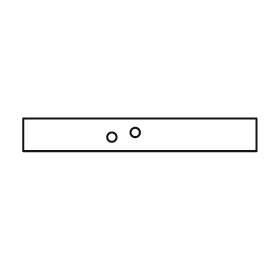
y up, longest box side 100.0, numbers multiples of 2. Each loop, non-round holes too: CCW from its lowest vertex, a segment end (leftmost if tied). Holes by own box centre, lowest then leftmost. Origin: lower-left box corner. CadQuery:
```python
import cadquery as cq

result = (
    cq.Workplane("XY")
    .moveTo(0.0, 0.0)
    .lineTo(100.0, 0.0)
    .lineTo(100.0, 14.0)
    .lineTo(0.0, 14.0)
    .close()
    .moveTo(38.0, 6.0)
    .circle(2.0)
    .moveTo(48.0, 8.0)
    .circle(2.0)
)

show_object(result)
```